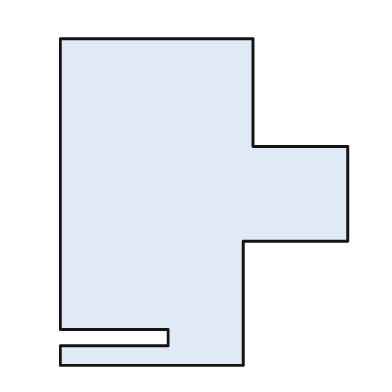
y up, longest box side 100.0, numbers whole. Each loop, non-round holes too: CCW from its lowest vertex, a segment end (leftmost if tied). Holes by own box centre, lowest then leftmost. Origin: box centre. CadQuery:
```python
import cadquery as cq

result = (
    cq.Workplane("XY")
    .moveTo(-44.0, -50.0)
    .lineTo(12.0, -50.0)
    .lineTo(12.0, -12.0)
    .lineTo(44.0, -12.0)
    .lineTo(44.0, 17.0)
    .lineTo(15.0, 17.0)
    .lineTo(15.0, 50.0)
    .lineTo(-44.0, 50.0)
    .lineTo(-44.0, -39.0)
    .lineTo(-11.0, -39.0)
    .lineTo(-11.0, -44.0)
    .lineTo(-44.0, -44.0)
    .close()
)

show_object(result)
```